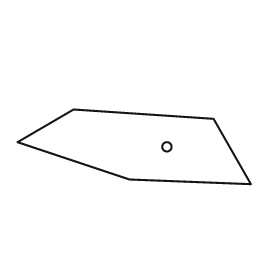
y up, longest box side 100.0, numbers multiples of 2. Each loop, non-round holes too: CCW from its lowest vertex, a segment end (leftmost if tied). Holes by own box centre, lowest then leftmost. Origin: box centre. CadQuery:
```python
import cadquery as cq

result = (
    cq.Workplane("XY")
    .moveTo(50.0, -16.0)
    .lineTo(34.0, 12.0)
    .lineTo(-26.0, 16.0)
    .lineTo(-50.0, 2.0)
    .lineTo(-2.0, -14.0)
    .close()
    .moveTo(14.0, 0.0)
    .circle(2.0)
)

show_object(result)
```